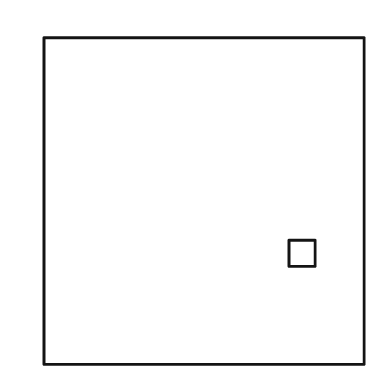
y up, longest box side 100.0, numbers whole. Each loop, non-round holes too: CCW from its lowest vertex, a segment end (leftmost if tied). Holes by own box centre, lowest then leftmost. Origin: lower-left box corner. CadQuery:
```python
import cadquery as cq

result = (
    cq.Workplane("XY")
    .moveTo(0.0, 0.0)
    .lineTo(98.0, 0.0)
    .lineTo(98.0, 100.0)
    .lineTo(0.0, 100.0)
    .close()
    .moveTo(75.0, 30.0)
    .lineTo(83.0, 30.0)
    .lineTo(83.0, 38.0)
    .lineTo(75.0, 38.0)
    .close()
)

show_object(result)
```